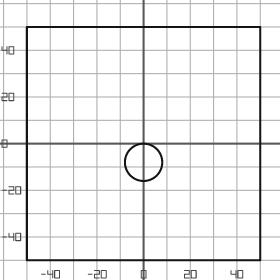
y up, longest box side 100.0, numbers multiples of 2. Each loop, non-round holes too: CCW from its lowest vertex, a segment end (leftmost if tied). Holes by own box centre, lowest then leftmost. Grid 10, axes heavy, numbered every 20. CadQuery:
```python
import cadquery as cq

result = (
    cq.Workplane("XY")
    .moveTo(-50.0, -50.0)
    .lineTo(50.0, -50.0)
    .lineTo(50.0, 50.0)
    .lineTo(-50.0, 50.0)
    .close()
    .moveTo(0.0, -8.0)
    .circle(8.0)
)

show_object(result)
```